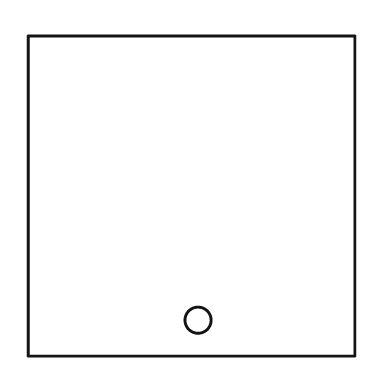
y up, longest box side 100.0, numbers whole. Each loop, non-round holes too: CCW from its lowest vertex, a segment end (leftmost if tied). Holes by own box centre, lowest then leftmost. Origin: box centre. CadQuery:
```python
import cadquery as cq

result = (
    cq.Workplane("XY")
    .moveTo(-50.0, -49.0)
    .lineTo(50.0, -49.0)
    .lineTo(50.0, 49.0)
    .lineTo(-50.0, 49.0)
    .close()
    .moveTo(2.0, -38.0)
    .circle(4.0)
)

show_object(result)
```